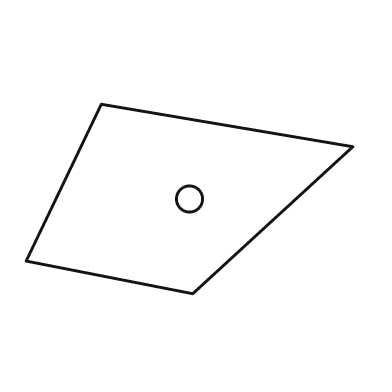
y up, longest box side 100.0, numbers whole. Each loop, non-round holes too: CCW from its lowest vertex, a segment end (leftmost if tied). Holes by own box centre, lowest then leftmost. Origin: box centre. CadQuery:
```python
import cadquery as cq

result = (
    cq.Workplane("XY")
    .moveTo(1.0, -29.0)
    .lineTo(50.0, 16.0)
    .lineTo(-27.0, 29.0)
    .lineTo(-50.0, -19.0)
    .close()
    .moveTo(0.0, 0.0)
    .circle(4.0)
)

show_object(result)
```